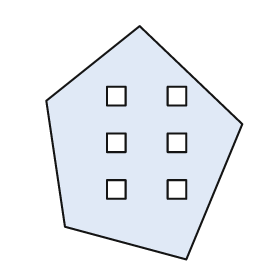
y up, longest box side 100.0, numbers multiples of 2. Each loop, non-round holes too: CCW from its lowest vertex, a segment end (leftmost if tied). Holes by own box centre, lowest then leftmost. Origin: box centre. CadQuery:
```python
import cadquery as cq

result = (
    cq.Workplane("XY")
    .moveTo(18.0, -50.0)
    .lineTo(42.0, 8.0)
    .lineTo(-2.0, 50.0)
    .lineTo(-42.0, 18.0)
    .lineTo(-34.0, -36.0)
    .close()
    .moveTo(-16.0, -24.0)
    .lineTo(-8.0, -24.0)
    .lineTo(-8.0, -16.0)
    .lineTo(-16.0, -16.0)
    .close()
    .moveTo(10.0, -24.0)
    .lineTo(18.0, -24.0)
    .lineTo(18.0, -16.0)
    .lineTo(10.0, -16.0)
    .close()
    .moveTo(-16.0, -4.0)
    .lineTo(-8.0, -4.0)
    .lineTo(-8.0, 4.0)
    .lineTo(-16.0, 4.0)
    .close()
    .moveTo(10.0, -4.0)
    .lineTo(18.0, -4.0)
    .lineTo(18.0, 4.0)
    .lineTo(10.0, 4.0)
    .close()
    .moveTo(-16.0, 16.0)
    .lineTo(-8.0, 16.0)
    .lineTo(-8.0, 24.0)
    .lineTo(-16.0, 24.0)
    .close()
    .moveTo(10.0, 16.0)
    .lineTo(18.0, 16.0)
    .lineTo(18.0, 24.0)
    .lineTo(10.0, 24.0)
    .close()
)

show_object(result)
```